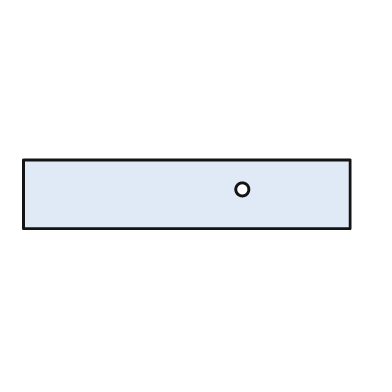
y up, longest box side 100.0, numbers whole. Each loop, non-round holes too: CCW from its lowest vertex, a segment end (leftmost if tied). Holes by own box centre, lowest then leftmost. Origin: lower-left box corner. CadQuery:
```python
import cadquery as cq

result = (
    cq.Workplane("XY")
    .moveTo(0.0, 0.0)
    .lineTo(100.0, 0.0)
    .lineTo(100.0, 21.0)
    .lineTo(0.0, 21.0)
    .close()
    .moveTo(67.0, 12.0)
    .circle(2.0)
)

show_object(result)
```